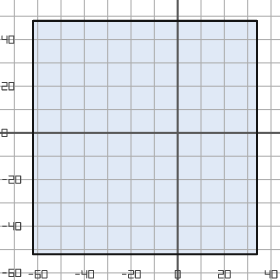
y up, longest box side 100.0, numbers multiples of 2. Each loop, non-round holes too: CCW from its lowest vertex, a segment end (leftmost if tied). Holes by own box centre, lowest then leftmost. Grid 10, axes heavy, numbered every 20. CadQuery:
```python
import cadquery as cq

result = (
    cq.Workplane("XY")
    .moveTo(-62.0, -52.0)
    .lineTo(34.0, -52.0)
    .lineTo(34.0, 48.0)
    .lineTo(-62.0, 48.0)
    .close()
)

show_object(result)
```